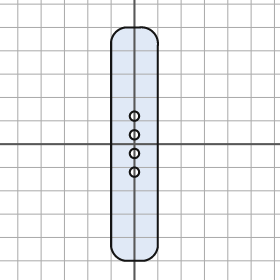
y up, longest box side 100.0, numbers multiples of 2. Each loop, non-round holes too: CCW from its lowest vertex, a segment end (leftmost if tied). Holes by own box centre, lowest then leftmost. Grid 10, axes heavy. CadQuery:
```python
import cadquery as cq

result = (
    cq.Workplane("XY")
    .moveTo(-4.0, -50.0)
    .lineTo(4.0, -50.0)
    .threePointArc((8.0, -48.0), (10.0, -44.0))
    .lineTo(10.0, 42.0)
    .threePointArc((8.0, 48.0), (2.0, 50.0))
    .lineTo(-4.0, 50.0)
    .threePointArc((-8.0, 48.0), (-10.0, 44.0))
    .lineTo(-10.0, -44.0)
    .threePointArc((-8.0, -48.0), (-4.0, -50.0))
    .close()
    .moveTo(0.0, -12.0)
    .circle(2.0)
    .moveTo(0.0, -4.0)
    .circle(2.0)
    .moveTo(0.0, 4.0)
    .circle(2.0)
    .moveTo(0.0, 12.0)
    .circle(2.0)
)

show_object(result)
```